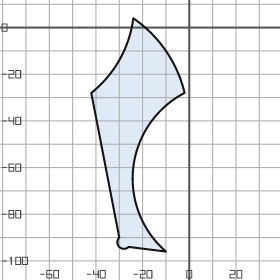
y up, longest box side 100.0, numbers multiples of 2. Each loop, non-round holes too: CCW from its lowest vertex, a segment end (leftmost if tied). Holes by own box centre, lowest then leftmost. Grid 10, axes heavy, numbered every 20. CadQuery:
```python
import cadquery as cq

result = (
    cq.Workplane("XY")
    .moveTo(-10.0, -96.0)
    .threePointArc((-24.0, -60.0), (-2.0, -28.0))
    .threePointArc((-10.0, -10.0), (-24.0, 4.0))
    .threePointArc((-30.0, -14.0), (-42.0, -28.0))
    .lineTo(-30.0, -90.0)
    .threePointArc((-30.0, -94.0), (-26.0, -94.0))
    .close()
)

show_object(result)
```